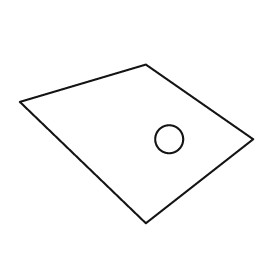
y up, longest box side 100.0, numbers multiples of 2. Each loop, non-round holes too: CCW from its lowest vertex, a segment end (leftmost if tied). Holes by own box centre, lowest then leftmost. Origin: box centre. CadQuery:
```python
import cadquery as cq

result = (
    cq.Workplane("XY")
    .moveTo(4.0, -34.0)
    .lineTo(50.0, 2.0)
    .lineTo(4.0, 34.0)
    .lineTo(-50.0, 18.0)
    .close()
    .moveTo(14.0, 2.0)
    .circle(6.0)
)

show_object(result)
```